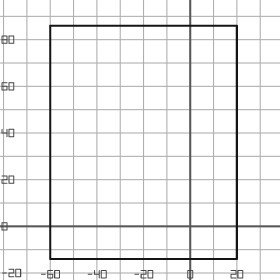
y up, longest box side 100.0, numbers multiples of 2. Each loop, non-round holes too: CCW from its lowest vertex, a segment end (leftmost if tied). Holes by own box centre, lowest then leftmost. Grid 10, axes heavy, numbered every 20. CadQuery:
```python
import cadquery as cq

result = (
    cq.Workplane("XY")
    .moveTo(-60.0, -14.0)
    .lineTo(20.0, -14.0)
    .lineTo(20.0, 86.0)
    .lineTo(-60.0, 86.0)
    .close()
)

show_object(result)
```